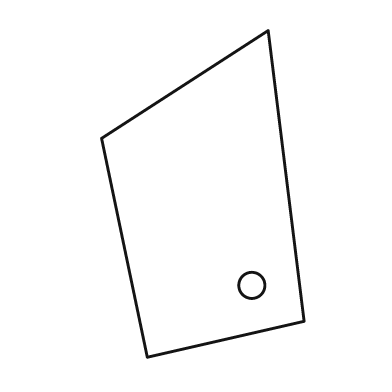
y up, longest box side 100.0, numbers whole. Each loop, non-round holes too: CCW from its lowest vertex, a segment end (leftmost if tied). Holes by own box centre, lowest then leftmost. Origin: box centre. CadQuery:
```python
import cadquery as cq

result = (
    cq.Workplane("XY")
    .moveTo(-17.0, -50.0)
    .lineTo(31.0, -39.0)
    .lineTo(20.0, 50.0)
    .lineTo(-31.0, 17.0)
    .close()
    .moveTo(15.0, -28.0)
    .circle(4.0)
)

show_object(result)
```